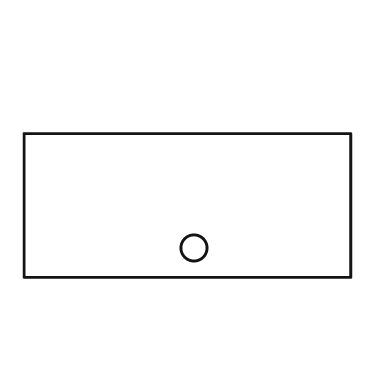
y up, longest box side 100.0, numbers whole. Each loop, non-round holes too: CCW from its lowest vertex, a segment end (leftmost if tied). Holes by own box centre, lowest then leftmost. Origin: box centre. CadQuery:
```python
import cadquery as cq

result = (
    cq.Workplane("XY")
    .moveTo(-50.0, -22.0)
    .lineTo(50.0, -22.0)
    .lineTo(50.0, 22.0)
    .lineTo(-50.0, 22.0)
    .close()
    .moveTo(2.0, -13.0)
    .circle(4.0)
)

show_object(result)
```